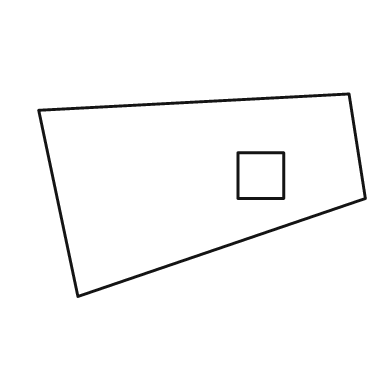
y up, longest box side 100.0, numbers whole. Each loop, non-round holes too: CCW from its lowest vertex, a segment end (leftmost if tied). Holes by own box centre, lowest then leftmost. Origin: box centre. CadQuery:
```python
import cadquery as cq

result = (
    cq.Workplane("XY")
    .moveTo(-38.0, -31.0)
    .lineTo(50.0, -1.0)
    .lineTo(45.0, 31.0)
    .lineTo(-50.0, 26.0)
    .close()
    .moveTo(11.0, -1.0)
    .lineTo(25.0, -1.0)
    .lineTo(25.0, 13.0)
    .lineTo(11.0, 13.0)
    .close()
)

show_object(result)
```